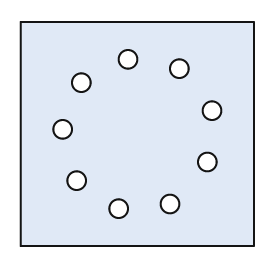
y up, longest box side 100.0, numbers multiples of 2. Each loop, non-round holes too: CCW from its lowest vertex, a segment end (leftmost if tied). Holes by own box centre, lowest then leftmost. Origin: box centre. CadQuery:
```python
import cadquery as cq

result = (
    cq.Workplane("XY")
    .moveTo(-50.0, -48.0)
    .lineTo(50.0, -48.0)
    .lineTo(50.0, 48.0)
    .lineTo(-50.0, 48.0)
    .close()
    .moveTo(-8.0, -32.0)
    .circle(4.0)
    .moveTo(14.0, -30.0)
    .circle(4.0)
    .moveTo(-26.0, -20.0)
    .circle(4.0)
    .moveTo(30.0, -12.0)
    .circle(4.0)
    .moveTo(-32.0, 2.0)
    .circle(4.0)
    .moveTo(32.0, 10.0)
    .circle(4.0)
    .moveTo(-24.0, 22.0)
    .circle(4.0)
    .moveTo(18.0, 28.0)
    .circle(4.0)
    .moveTo(-4.0, 32.0)
    .circle(4.0)
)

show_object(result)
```